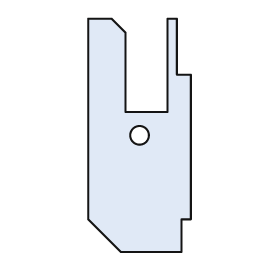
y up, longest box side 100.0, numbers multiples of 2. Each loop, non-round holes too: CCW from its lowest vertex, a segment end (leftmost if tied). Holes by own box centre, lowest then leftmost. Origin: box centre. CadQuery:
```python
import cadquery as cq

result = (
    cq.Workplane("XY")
    .moveTo(-8.0, -50.0)
    .lineTo(18.0, -50.0)
    .lineTo(18.0, -36.0)
    .lineTo(22.0, -36.0)
    .lineTo(22.0, 26.0)
    .lineTo(16.0, 26.0)
    .lineTo(16.0, 50.0)
    .lineTo(12.0, 50.0)
    .lineTo(12.0, 10.0)
    .lineTo(-6.0, 10.0)
    .lineTo(-6.0, 44.0)
    .lineTo(-12.0, 50.0)
    .lineTo(-22.0, 50.0)
    .lineTo(-22.0, -36.0)
    .close()
    .moveTo(0.0, 0.0)
    .circle(4.0)
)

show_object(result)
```